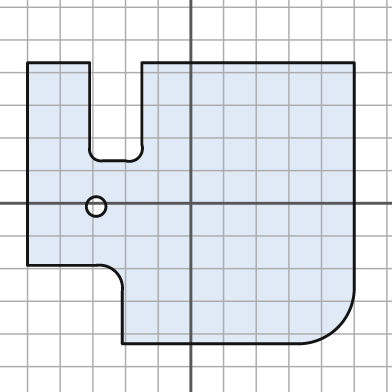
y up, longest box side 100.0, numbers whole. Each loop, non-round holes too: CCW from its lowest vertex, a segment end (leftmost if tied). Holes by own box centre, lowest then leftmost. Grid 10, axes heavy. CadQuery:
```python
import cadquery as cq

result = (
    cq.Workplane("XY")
    .moveTo(-21.0, -43.0)
    .lineTo(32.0, -43.0)
    .threePointArc((45.0, -38.0), (50.0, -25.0))
    .lineTo(50.0, 43.0)
    .lineTo(-15.0, 43.0)
    .lineTo(-15.0, 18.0)
    .threePointArc((-16.0, 14.0), (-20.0, 13.0))
    .lineTo(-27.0, 13.0)
    .threePointArc((-30.0, 14.0), (-31.0, 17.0))
    .lineTo(-31.0, 43.0)
    .lineTo(-50.0, 43.0)
    .lineTo(-50.0, -19.0)
    .lineTo(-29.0, -19.0)
    .threePointArc((-23.0, -21.0), (-21.0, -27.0))
    .close()
    .moveTo(-29.0, -1.0)
    .circle(3.0)
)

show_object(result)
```